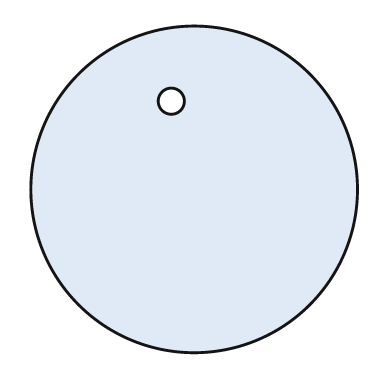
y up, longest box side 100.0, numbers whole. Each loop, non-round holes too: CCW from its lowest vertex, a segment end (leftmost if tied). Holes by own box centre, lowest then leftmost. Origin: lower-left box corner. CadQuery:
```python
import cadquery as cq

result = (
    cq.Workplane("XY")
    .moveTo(50.0, 50.0)
    .circle(50.0)
    .moveTo(43.0, 77.0)
    .circle(4.0)
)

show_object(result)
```